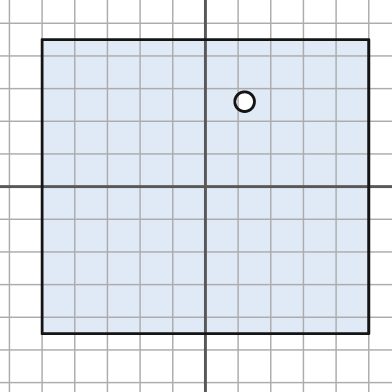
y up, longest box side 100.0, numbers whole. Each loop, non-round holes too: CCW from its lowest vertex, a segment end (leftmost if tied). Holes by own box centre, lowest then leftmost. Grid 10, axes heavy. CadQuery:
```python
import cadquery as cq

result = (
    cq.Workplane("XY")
    .moveTo(-50.0, -45.0)
    .lineTo(50.0, -45.0)
    .lineTo(50.0, 45.0)
    .lineTo(-50.0, 45.0)
    .close()
    .moveTo(12.0, 26.0)
    .circle(3.0)
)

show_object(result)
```